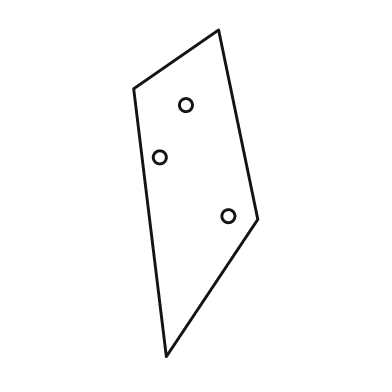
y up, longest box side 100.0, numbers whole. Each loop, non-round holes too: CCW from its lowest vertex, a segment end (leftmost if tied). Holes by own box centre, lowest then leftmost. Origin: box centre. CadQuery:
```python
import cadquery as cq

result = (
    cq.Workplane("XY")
    .moveTo(-9.0, -50.0)
    .lineTo(19.0, -8.0)
    .lineTo(7.0, 50.0)
    .lineTo(-19.0, 32.0)
    .close()
    .moveTo(10.0, -7.0)
    .circle(2.0)
    .moveTo(-11.0, 11.0)
    .circle(2.0)
    .moveTo(-3.0, 27.0)
    .circle(2.0)
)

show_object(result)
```